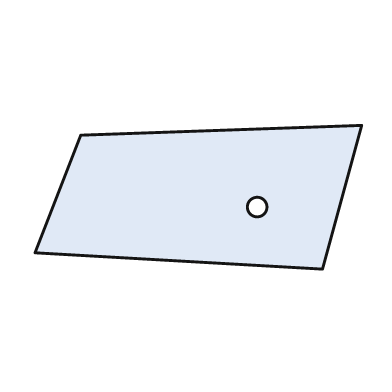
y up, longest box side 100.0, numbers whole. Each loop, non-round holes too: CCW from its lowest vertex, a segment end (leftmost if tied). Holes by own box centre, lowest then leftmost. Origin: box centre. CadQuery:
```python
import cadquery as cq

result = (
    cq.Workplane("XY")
    .moveTo(38.0, -22.0)
    .lineTo(50.0, 22.0)
    .lineTo(-36.0, 19.0)
    .lineTo(-50.0, -17.0)
    .close()
    .moveTo(18.0, -3.0)
    .circle(3.0)
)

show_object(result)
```